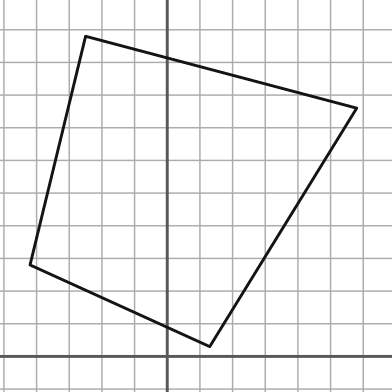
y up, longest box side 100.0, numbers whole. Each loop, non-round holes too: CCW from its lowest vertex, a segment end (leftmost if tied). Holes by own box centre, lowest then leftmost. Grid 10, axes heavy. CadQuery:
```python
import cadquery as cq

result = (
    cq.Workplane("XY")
    .moveTo(13.0, 3.0)
    .lineTo(58.0, 76.0)
    .lineTo(-25.0, 98.0)
    .lineTo(-42.0, 28.0)
    .close()
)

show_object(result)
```